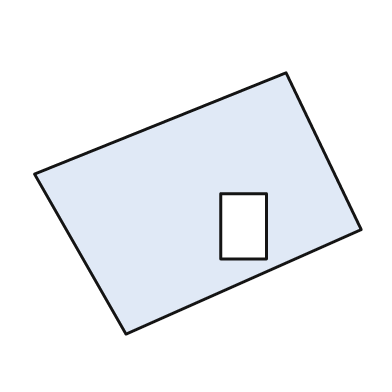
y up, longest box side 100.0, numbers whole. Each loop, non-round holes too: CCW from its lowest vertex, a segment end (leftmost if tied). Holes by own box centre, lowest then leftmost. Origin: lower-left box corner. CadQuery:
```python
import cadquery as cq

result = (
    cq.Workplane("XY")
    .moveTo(28.0, 0.0)
    .lineTo(100.0, 32.0)
    .lineTo(77.0, 80.0)
    .lineTo(0.0, 49.0)
    .close()
    .moveTo(57.0, 23.0)
    .lineTo(71.0, 23.0)
    .lineTo(71.0, 43.0)
    .lineTo(57.0, 43.0)
    .close()
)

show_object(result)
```